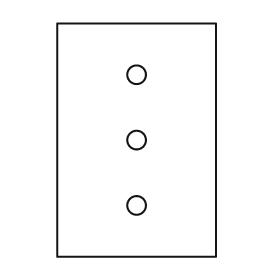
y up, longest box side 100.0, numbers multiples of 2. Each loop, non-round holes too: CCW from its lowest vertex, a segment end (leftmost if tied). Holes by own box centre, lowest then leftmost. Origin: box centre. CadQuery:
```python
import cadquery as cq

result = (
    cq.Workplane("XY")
    .moveTo(-34.0, -50.0)
    .lineTo(34.0, -50.0)
    .lineTo(34.0, 50.0)
    .lineTo(-34.0, 50.0)
    .close()
    .moveTo(0.0, -28.0)
    .circle(4.0)
    .moveTo(0.0, 0.0)
    .circle(4.0)
    .moveTo(0.0, 28.0)
    .circle(4.0)
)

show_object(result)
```